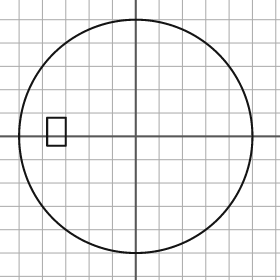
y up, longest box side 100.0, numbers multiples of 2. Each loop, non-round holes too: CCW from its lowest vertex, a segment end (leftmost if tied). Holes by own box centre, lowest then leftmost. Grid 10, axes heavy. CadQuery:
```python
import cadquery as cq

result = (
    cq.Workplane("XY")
    .moveTo(0.0, 0.0)
    .circle(50.0)
    .moveTo(-38.0, -4.0)
    .lineTo(-30.0, -4.0)
    .lineTo(-30.0, 8.0)
    .lineTo(-38.0, 8.0)
    .close()
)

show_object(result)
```